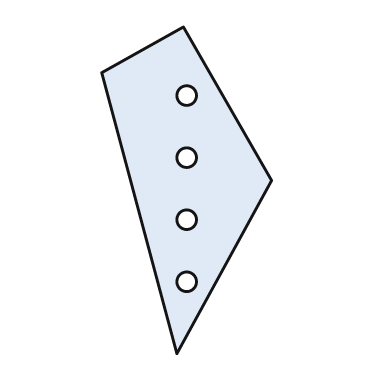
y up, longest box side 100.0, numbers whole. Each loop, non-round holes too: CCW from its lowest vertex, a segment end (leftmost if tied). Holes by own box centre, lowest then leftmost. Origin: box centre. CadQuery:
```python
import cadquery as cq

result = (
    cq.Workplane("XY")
    .moveTo(-3.0, -50.0)
    .lineTo(26.0, 3.0)
    .lineTo(-1.0, 50.0)
    .lineTo(-26.0, 36.0)
    .close()
    .moveTo(0.0, -28.0)
    .circle(3.0)
    .moveTo(0.0, -9.0)
    .circle(3.0)
    .moveTo(0.0, 10.0)
    .circle(3.0)
    .moveTo(0.0, 29.0)
    .circle(3.0)
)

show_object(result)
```